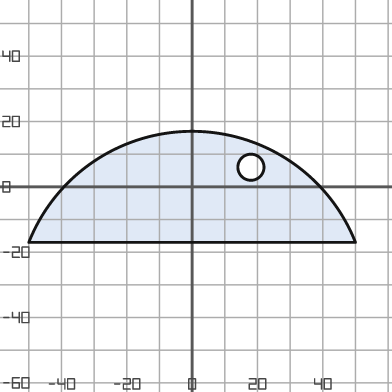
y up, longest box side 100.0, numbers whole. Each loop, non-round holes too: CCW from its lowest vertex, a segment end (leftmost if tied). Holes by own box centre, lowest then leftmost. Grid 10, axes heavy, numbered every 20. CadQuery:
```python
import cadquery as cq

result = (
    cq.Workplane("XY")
    .moveTo(-50.0, -17.0)
    .lineTo(50.0, -17.0)
    .threePointArc((0.0, 17.0), (-50.0, -17.0))
    .close()
    .moveTo(18.0, 6.0)
    .circle(4.0)
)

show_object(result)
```